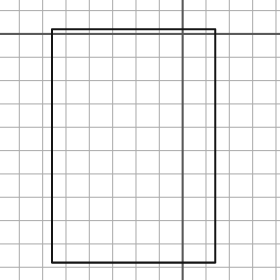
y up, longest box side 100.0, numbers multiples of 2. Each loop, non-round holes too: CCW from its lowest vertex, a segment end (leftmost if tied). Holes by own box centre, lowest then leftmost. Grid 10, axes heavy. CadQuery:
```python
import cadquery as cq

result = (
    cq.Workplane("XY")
    .moveTo(-56.0, -98.0)
    .lineTo(14.0, -98.0)
    .lineTo(14.0, 2.0)
    .lineTo(-56.0, 2.0)
    .close()
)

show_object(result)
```